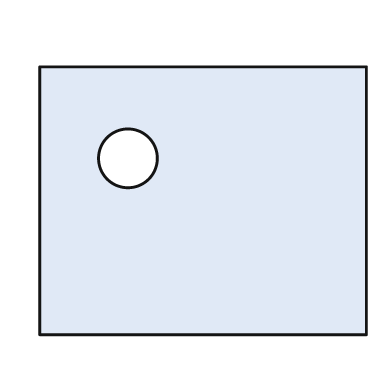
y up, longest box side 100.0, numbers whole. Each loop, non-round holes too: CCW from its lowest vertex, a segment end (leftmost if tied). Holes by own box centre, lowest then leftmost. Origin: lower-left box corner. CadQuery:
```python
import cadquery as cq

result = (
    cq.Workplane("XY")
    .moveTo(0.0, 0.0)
    .lineTo(100.0, 0.0)
    .lineTo(100.0, 82.0)
    .lineTo(0.0, 82.0)
    .close()
    .moveTo(27.0, 54.0)
    .circle(9.0)
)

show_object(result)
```